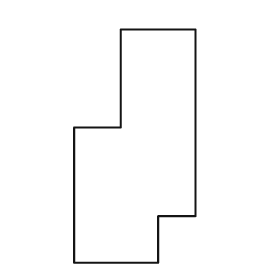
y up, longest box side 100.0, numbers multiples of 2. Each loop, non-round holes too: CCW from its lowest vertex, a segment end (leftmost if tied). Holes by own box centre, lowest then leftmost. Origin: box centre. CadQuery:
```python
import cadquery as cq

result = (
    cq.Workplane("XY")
    .moveTo(-26.0, -50.0)
    .lineTo(10.0, -50.0)
    .lineTo(10.0, -30.0)
    .lineTo(26.0, -30.0)
    .lineTo(26.0, 50.0)
    .lineTo(-6.0, 50.0)
    .lineTo(-6.0, 8.0)
    .lineTo(-26.0, 8.0)
    .close()
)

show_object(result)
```